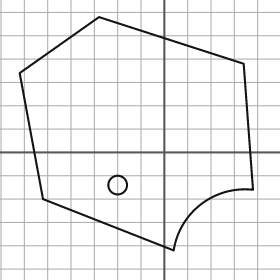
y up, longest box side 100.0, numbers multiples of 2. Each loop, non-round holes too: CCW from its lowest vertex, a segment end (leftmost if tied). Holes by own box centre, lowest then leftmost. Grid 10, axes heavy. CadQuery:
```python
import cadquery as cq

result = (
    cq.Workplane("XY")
    .moveTo(4.0, -42.0)
    .threePointArc((16.0, -22.0), (38.0, -16.0))
    .lineTo(34.0, 38.0)
    .lineTo(-28.0, 58.0)
    .lineTo(-62.0, 34.0)
    .lineTo(-52.0, -20.0)
    .close()
    .moveTo(-20.0, -14.0)
    .circle(4.0)
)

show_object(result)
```